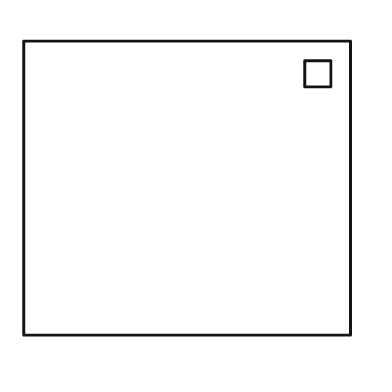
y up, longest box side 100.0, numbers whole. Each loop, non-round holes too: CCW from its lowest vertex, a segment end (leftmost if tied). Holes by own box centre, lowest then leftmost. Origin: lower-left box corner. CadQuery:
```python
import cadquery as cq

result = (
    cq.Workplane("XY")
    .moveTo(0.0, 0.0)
    .lineTo(100.0, 0.0)
    .lineTo(100.0, 90.0)
    .lineTo(0.0, 90.0)
    .close()
    .moveTo(86.0, 76.0)
    .lineTo(94.0, 76.0)
    .lineTo(94.0, 84.0)
    .lineTo(86.0, 84.0)
    .close()
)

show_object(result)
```